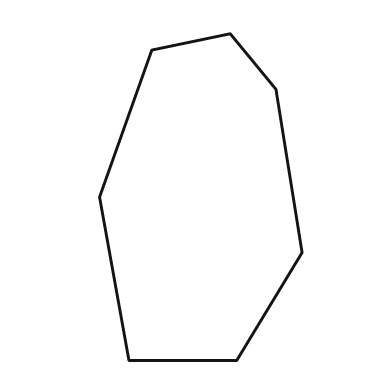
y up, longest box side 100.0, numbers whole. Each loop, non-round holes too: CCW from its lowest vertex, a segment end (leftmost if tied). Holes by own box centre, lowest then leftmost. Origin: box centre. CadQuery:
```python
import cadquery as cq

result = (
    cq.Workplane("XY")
    .moveTo(-22.0, -50.0)
    .lineTo(11.0, -50.0)
    .lineTo(31.0, -17.0)
    .lineTo(23.0, 33.0)
    .lineTo(9.0, 50.0)
    .lineTo(-15.0, 45.0)
    .lineTo(-31.0, 0.0)
    .close()
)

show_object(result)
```